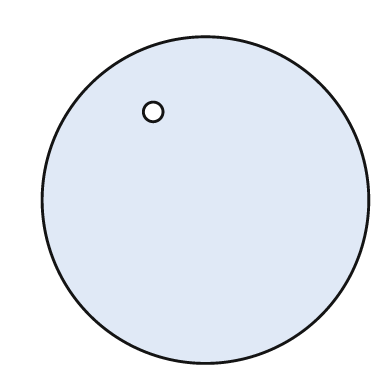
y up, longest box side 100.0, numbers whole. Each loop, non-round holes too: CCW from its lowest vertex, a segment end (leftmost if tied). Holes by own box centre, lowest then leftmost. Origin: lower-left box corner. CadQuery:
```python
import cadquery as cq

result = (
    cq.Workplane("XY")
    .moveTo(50.0, 50.0)
    .circle(50.0)
    .moveTo(34.0, 77.0)
    .circle(3.0)
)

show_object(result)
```